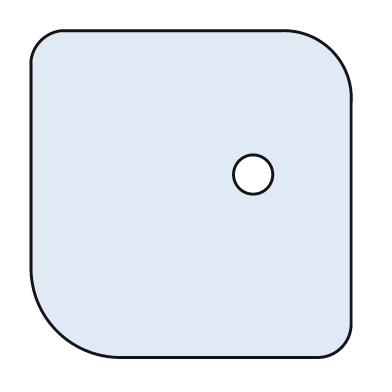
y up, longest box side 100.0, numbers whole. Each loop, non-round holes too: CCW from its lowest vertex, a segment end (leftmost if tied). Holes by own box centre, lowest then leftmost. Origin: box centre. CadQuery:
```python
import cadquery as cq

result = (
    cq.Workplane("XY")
    .moveTo(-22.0, -50.0)
    .lineTo(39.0, -50.0)
    .threePointArc((46.0, -47.0), (49.0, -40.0))
    .lineTo(49.0, 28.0)
    .threePointArc((43.0, 44.0), (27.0, 50.0))
    .lineTo(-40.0, 50.0)
    .threePointArc((-46.0, 47.0), (-49.0, 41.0))
    .lineTo(-49.0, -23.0)
    .threePointArc((-41.0, -42.0), (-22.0, -50.0))
    .close()
    .moveTo(19.0, 6.0)
    .circle(6.0)
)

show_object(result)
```